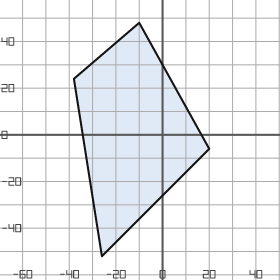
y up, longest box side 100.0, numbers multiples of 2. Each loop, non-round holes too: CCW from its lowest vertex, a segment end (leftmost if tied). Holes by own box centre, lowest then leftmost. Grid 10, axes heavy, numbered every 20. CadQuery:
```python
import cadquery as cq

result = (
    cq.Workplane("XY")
    .moveTo(-26.0, -52.0)
    .lineTo(20.0, -6.0)
    .lineTo(-10.0, 48.0)
    .lineTo(-38.0, 24.0)
    .close()
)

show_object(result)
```